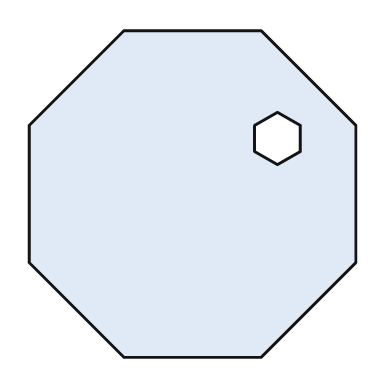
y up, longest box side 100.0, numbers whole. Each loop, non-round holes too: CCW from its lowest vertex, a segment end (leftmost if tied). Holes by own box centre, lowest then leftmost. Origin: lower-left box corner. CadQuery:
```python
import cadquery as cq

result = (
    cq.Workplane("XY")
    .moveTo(29.0, 0.0)
    .lineTo(71.0, 0.0)
    .lineTo(100.0, 29.0)
    .lineTo(100.0, 71.0)
    .lineTo(71.0, 100.0)
    .lineTo(29.0, 100.0)
    .lineTo(0.0, 71.0)
    .lineTo(0.0, 29.0)
    .close()
    .moveTo(76.0, 59.0)
    .lineTo(83.0, 63.0)
    .lineTo(83.0, 71.0)
    .lineTo(76.0, 75.0)
    .lineTo(69.0, 71.0)
    .lineTo(69.0, 63.0)
    .close()
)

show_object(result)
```